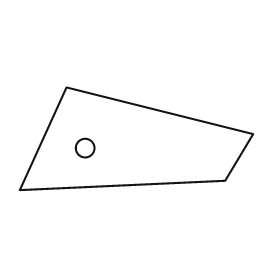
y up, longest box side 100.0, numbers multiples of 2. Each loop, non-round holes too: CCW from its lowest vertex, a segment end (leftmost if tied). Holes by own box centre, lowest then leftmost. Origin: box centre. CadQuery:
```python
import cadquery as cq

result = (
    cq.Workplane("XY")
    .moveTo(-50.0, -22.0)
    .lineTo(38.0, -18.0)
    .lineTo(50.0, 2.0)
    .lineTo(-30.0, 22.0)
    .close()
    .moveTo(-22.0, -4.0)
    .circle(4.0)
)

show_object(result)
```